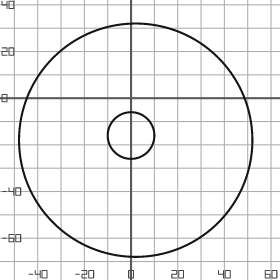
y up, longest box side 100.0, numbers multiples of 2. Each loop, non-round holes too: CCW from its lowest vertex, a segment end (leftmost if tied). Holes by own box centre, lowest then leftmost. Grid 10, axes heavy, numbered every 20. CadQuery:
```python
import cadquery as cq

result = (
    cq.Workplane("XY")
    .moveTo(2.0, -18.0)
    .circle(50.0)
    .moveTo(0.0, -16.0)
    .circle(10.0)
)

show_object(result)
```